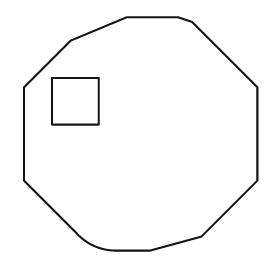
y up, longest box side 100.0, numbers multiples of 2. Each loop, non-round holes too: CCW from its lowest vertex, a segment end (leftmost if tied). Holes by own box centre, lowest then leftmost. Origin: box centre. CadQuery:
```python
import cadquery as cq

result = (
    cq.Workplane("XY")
    .moveTo(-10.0, -50.0)
    .lineTo(4.0, -50.0)
    .lineTo(26.0, -44.0)
    .lineTo(50.0, -20.0)
    .lineTo(50.0, 20.0)
    .lineTo(22.0, 48.0)
    .lineTo(16.0, 50.0)
    .lineTo(-6.0, 50.0)
    .lineTo(-30.0, 40.0)
    .lineTo(-50.0, 20.0)
    .lineTo(-50.0, -20.0)
    .lineTo(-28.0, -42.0)
    .threePointArc((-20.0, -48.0), (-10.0, -50.0))
    .close()
    .moveTo(-38.0, 4.0)
    .lineTo(-18.0, 4.0)
    .lineTo(-18.0, 24.0)
    .lineTo(-38.0, 24.0)
    .close()
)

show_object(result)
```